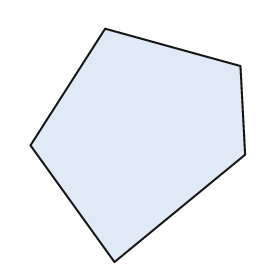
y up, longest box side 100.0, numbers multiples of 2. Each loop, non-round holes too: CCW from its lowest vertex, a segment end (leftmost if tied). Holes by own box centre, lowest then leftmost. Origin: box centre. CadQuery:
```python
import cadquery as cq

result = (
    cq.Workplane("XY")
    .moveTo(-10.0, -50.0)
    .lineTo(46.0, -4.0)
    .lineTo(44.0, 34.0)
    .lineTo(-14.0, 50.0)
    .lineTo(-46.0, 0.0)
    .close()
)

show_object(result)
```